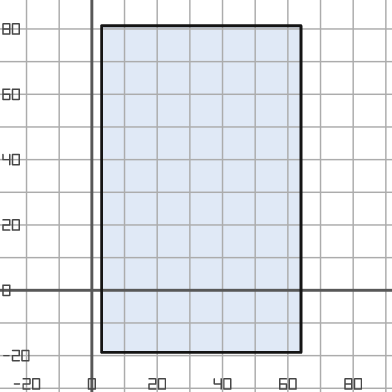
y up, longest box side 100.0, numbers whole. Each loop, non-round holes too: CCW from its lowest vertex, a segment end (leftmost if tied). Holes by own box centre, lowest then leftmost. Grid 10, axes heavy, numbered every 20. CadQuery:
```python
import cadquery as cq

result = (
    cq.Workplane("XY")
    .moveTo(3.0, -19.0)
    .lineTo(64.0, -19.0)
    .lineTo(64.0, 81.0)
    .lineTo(3.0, 81.0)
    .close()
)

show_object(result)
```